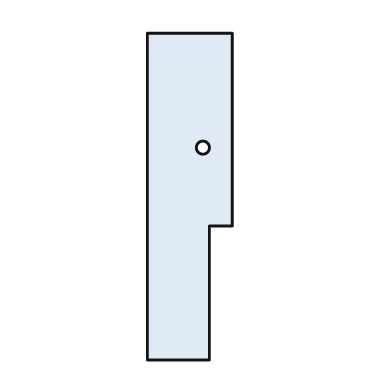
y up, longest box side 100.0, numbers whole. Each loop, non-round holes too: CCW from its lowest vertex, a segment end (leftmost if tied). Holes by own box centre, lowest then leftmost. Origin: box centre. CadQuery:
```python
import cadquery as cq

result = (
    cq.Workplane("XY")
    .moveTo(-13.0, -50.0)
    .lineTo(6.0, -50.0)
    .lineTo(6.0, -9.0)
    .lineTo(13.0, -9.0)
    .lineTo(13.0, 50.0)
    .lineTo(-13.0, 50.0)
    .close()
    .moveTo(4.0, 15.0)
    .circle(2.0)
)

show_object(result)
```